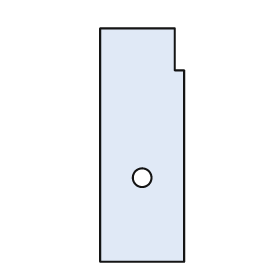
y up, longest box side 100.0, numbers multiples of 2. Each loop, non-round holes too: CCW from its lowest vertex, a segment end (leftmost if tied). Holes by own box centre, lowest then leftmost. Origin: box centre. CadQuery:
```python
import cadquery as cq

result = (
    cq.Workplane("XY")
    .moveTo(-18.0, -50.0)
    .lineTo(18.0, -50.0)
    .lineTo(18.0, 32.0)
    .lineTo(14.0, 32.0)
    .lineTo(14.0, 50.0)
    .lineTo(-18.0, 50.0)
    .close()
    .moveTo(0.0, -14.0)
    .circle(4.0)
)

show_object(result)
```